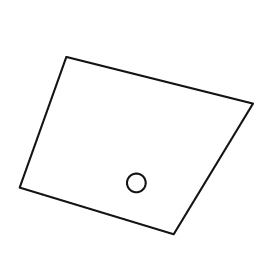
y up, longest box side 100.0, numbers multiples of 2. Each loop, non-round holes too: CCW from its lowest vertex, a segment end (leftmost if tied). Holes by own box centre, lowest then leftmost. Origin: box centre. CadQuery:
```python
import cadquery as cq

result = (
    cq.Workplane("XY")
    .moveTo(16.0, -38.0)
    .lineTo(50.0, 18.0)
    .lineTo(-30.0, 38.0)
    .lineTo(-50.0, -18.0)
    .close()
    .moveTo(0.0, -16.0)
    .circle(4.0)
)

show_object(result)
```